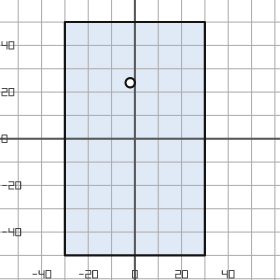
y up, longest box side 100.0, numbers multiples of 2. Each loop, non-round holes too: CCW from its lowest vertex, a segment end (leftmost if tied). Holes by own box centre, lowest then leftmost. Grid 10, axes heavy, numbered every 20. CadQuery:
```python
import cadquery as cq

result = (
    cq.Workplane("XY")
    .moveTo(-30.0, -50.0)
    .lineTo(30.0, -50.0)
    .lineTo(30.0, 50.0)
    .lineTo(-30.0, 50.0)
    .close()
    .moveTo(-2.0, 24.0)
    .circle(2.0)
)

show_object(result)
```